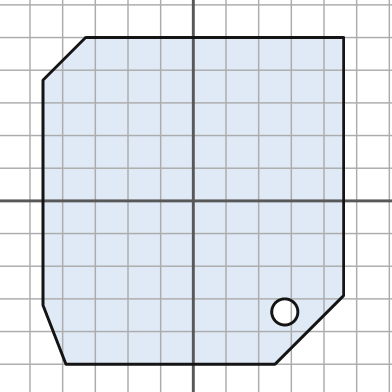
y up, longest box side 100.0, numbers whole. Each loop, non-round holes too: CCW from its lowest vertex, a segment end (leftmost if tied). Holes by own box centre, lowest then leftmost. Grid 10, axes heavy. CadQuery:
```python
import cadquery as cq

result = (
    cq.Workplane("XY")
    .moveTo(-39.0, -50.0)
    .lineTo(25.0, -50.0)
    .lineTo(46.0, -29.0)
    .lineTo(46.0, 50.0)
    .lineTo(-33.0, 50.0)
    .lineTo(-46.0, 37.0)
    .lineTo(-46.0, -32.0)
    .close()
    .moveTo(28.0, -34.0)
    .circle(4.0)
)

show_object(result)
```